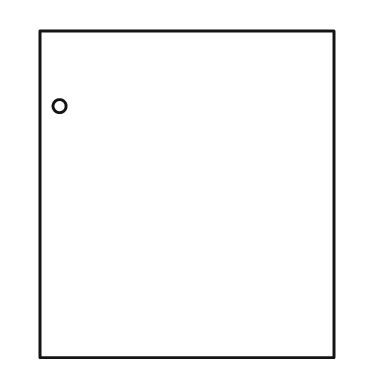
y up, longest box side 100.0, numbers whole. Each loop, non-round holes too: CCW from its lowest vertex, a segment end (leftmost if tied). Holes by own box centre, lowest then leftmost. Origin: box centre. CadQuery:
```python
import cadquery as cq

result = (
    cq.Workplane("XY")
    .moveTo(-45.0, -50.0)
    .lineTo(45.0, -50.0)
    .lineTo(45.0, 50.0)
    .lineTo(-45.0, 50.0)
    .close()
    .moveTo(-39.0, 27.0)
    .circle(2.0)
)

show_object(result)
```